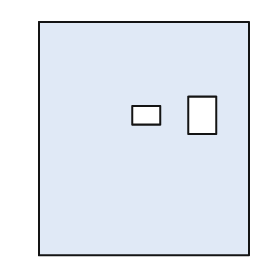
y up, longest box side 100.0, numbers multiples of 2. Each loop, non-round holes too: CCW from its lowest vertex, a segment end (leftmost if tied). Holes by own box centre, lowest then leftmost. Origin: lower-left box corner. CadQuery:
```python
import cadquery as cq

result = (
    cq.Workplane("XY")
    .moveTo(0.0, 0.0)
    .lineTo(90.0, 0.0)
    .lineTo(90.0, 100.0)
    .lineTo(0.0, 100.0)
    .close()
    .moveTo(40.0, 56.0)
    .lineTo(52.0, 56.0)
    .lineTo(52.0, 64.0)
    .lineTo(40.0, 64.0)
    .close()
    .moveTo(64.0, 52.0)
    .lineTo(76.0, 52.0)
    .lineTo(76.0, 68.0)
    .lineTo(64.0, 68.0)
    .close()
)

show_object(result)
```